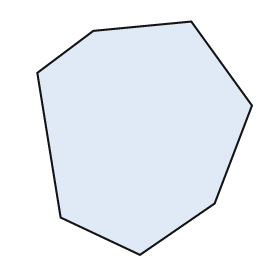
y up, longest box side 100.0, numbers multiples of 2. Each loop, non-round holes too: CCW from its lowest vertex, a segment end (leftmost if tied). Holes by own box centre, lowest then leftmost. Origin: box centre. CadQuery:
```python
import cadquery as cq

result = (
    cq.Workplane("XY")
    .moveTo(-2.0, -50.0)
    .lineTo(30.0, -28.0)
    .lineTo(46.0, 14.0)
    .lineTo(20.0, 50.0)
    .lineTo(-22.0, 46.0)
    .lineTo(-46.0, 28.0)
    .lineTo(-36.0, -34.0)
    .close()
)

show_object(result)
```